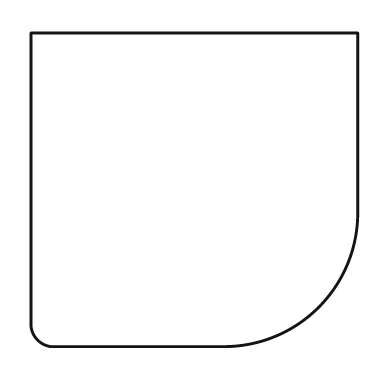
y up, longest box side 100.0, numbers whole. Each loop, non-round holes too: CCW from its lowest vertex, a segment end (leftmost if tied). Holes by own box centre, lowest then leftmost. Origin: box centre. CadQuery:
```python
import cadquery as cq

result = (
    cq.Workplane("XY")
    .moveTo(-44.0, -48.0)
    .lineTo(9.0, -48.0)
    .threePointArc((38.0, -36.0), (50.0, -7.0))
    .lineTo(50.0, 48.0)
    .lineTo(-50.0, 48.0)
    .lineTo(-50.0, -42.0)
    .threePointArc((-48.0, -46.0), (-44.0, -48.0))
    .close()
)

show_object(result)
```